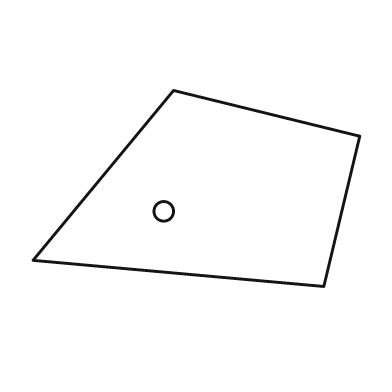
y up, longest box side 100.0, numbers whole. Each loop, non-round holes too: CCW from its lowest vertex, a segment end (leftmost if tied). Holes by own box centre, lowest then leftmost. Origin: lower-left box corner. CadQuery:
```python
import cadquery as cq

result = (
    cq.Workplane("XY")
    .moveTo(89.0, 0.0)
    .lineTo(100.0, 46.0)
    .lineTo(43.0, 60.0)
    .lineTo(0.0, 8.0)
    .close()
    .moveTo(40.0, 23.0)
    .circle(3.0)
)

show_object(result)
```